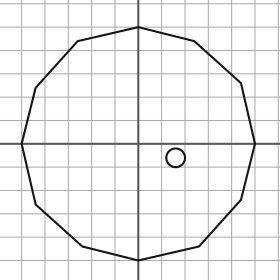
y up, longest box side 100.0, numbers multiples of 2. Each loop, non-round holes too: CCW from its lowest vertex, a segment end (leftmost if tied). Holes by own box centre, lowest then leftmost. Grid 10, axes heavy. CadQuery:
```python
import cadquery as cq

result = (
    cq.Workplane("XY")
    .moveTo(0.0, -50.0)
    .lineTo(26.0, -44.0)
    .lineTo(44.0, -24.0)
    .lineTo(50.0, 0.0)
    .lineTo(44.0, 26.0)
    .lineTo(24.0, 44.0)
    .lineTo(0.0, 50.0)
    .lineTo(-26.0, 44.0)
    .lineTo(-44.0, 24.0)
    .lineTo(-50.0, 0.0)
    .lineTo(-44.0, -26.0)
    .lineTo(-24.0, -44.0)
    .close()
    .moveTo(16.0, -6.0)
    .circle(4.0)
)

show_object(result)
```